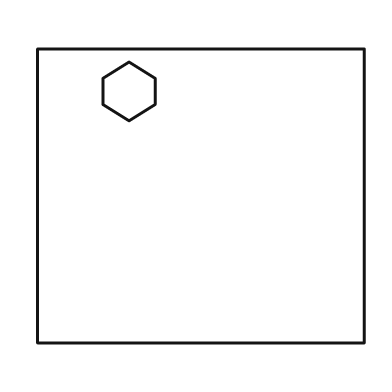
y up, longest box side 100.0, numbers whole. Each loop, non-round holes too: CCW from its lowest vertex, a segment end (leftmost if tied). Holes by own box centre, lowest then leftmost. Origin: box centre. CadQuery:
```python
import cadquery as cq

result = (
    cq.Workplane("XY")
    .moveTo(-50.0, -45.0)
    .lineTo(50.0, -45.0)
    .lineTo(50.0, 45.0)
    .lineTo(-50.0, 45.0)
    .close()
    .moveTo(-22.0, 23.0)
    .lineTo(-14.0, 28.0)
    .lineTo(-14.0, 36.0)
    .lineTo(-22.0, 41.0)
    .lineTo(-30.0, 36.0)
    .lineTo(-30.0, 28.0)
    .close()
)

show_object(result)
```